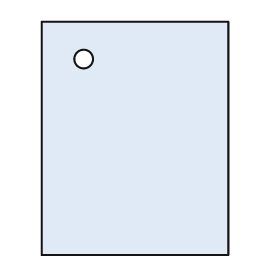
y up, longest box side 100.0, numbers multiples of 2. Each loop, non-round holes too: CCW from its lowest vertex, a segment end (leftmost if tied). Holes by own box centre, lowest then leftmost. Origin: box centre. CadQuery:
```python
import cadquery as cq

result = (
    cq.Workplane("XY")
    .moveTo(-40.0, -50.0)
    .lineTo(40.0, -50.0)
    .lineTo(40.0, 50.0)
    .lineTo(-40.0, 50.0)
    .close()
    .moveTo(-22.0, 34.0)
    .circle(4.0)
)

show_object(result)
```